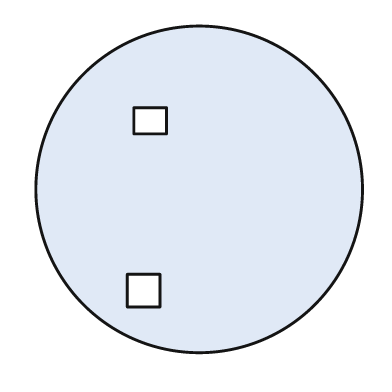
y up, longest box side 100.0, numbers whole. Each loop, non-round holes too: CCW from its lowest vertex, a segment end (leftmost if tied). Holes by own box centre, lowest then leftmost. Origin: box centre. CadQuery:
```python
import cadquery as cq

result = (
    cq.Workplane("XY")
    .moveTo(0.0, 0.0)
    .circle(50.0)
    .moveTo(-22.0, -36.0)
    .lineTo(-12.0, -36.0)
    .lineTo(-12.0, -26.0)
    .lineTo(-22.0, -26.0)
    .close()
    .moveTo(-20.0, 17.0)
    .lineTo(-10.0, 17.0)
    .lineTo(-10.0, 25.0)
    .lineTo(-20.0, 25.0)
    .close()
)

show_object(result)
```